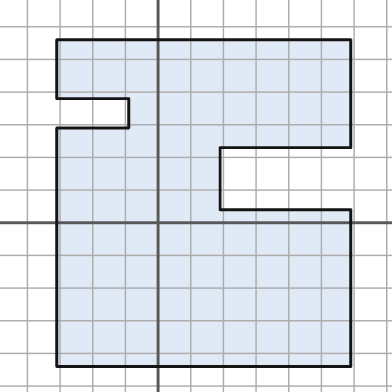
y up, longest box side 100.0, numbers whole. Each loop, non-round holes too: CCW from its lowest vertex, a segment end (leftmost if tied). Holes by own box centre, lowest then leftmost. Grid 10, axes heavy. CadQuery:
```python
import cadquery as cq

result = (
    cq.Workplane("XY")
    .moveTo(-31.0, -44.0)
    .lineTo(59.0, -44.0)
    .lineTo(59.0, 4.0)
    .lineTo(19.0, 4.0)
    .lineTo(19.0, 23.0)
    .lineTo(59.0, 23.0)
    .lineTo(59.0, 56.0)
    .lineTo(-31.0, 56.0)
    .lineTo(-31.0, 38.0)
    .lineTo(-9.0, 38.0)
    .lineTo(-9.0, 29.0)
    .lineTo(-31.0, 29.0)
    .close()
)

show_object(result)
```